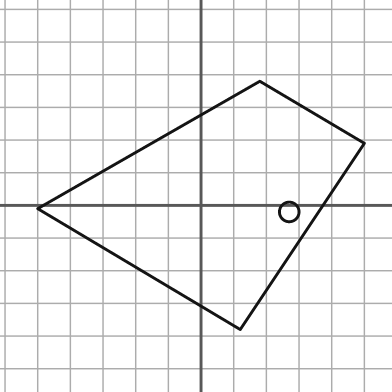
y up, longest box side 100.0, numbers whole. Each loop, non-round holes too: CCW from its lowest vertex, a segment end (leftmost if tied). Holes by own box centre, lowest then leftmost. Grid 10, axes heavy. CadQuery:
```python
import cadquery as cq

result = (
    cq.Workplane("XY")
    .moveTo(12.0, -38.0)
    .lineTo(50.0, 19.0)
    .lineTo(18.0, 38.0)
    .lineTo(-50.0, -1.0)
    .close()
    .moveTo(27.0, -2.0)
    .circle(3.0)
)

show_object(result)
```